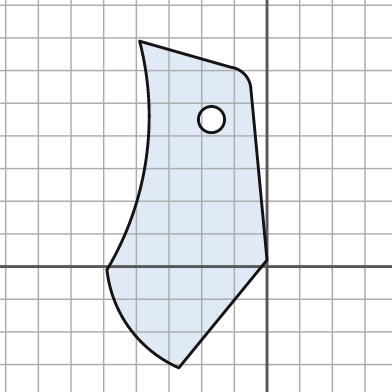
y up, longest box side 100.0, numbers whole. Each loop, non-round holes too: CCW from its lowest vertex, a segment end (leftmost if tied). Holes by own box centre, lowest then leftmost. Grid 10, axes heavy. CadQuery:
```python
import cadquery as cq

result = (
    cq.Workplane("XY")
    .moveTo(-27.0, -31.0)
    .lineTo(0.0, 2.0)
    .lineTo(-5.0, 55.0)
    .threePointArc((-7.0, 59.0), (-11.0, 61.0))
    .lineTo(-39.0, 69.0)
    .threePointArc((-37.0, 33.0), (-49.0, -1.0))
    .threePointArc((-42.0, -19.0), (-27.0, -31.0))
    .close()
    .moveTo(-17.0, 45.0)
    .circle(4.0)
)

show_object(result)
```